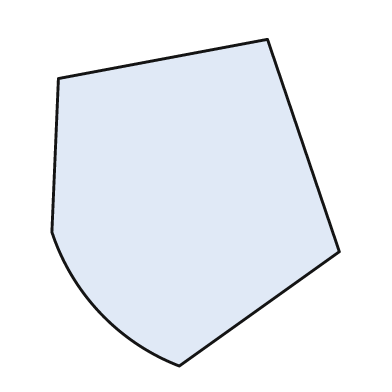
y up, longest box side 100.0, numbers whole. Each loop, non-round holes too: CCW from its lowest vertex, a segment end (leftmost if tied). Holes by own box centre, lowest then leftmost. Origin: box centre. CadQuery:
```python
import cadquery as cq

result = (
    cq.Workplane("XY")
    .moveTo(-5.0, -50.0)
    .lineTo(44.0, -15.0)
    .lineTo(22.0, 50.0)
    .lineTo(-42.0, 38.0)
    .lineTo(-44.0, -9.0)
    .threePointArc((-29.0, -34.0), (-5.0, -50.0))
    .close()
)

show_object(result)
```